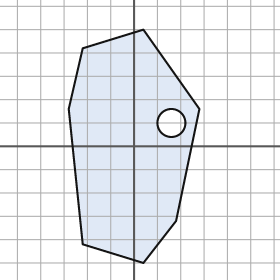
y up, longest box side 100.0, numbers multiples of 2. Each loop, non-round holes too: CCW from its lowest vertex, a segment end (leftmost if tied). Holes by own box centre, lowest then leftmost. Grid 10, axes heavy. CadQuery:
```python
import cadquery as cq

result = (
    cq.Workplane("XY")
    .moveTo(4.0, -50.0)
    .lineTo(18.0, -32.0)
    .lineTo(28.0, 16.0)
    .lineTo(4.0, 50.0)
    .lineTo(-22.0, 42.0)
    .lineTo(-28.0, 16.0)
    .lineTo(-22.0, -42.0)
    .close()
    .moveTo(16.0, 10.0)
    .circle(6.0)
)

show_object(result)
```